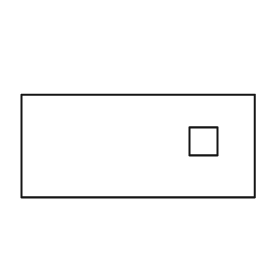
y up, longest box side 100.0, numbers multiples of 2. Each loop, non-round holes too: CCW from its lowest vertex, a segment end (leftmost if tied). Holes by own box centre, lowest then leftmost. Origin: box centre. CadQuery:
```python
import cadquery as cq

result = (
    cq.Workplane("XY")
    .moveTo(-50.0, -22.0)
    .lineTo(50.0, -22.0)
    .lineTo(50.0, 22.0)
    .lineTo(-50.0, 22.0)
    .close()
    .moveTo(22.0, -4.0)
    .lineTo(34.0, -4.0)
    .lineTo(34.0, 8.0)
    .lineTo(22.0, 8.0)
    .close()
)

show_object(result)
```